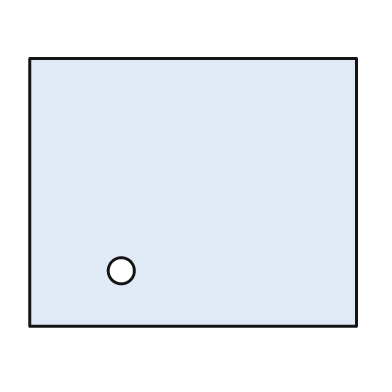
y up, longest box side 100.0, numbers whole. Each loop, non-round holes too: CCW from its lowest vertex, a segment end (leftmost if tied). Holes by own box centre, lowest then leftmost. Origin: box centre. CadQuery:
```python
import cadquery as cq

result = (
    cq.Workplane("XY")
    .moveTo(-50.0, -41.0)
    .lineTo(50.0, -41.0)
    .lineTo(50.0, 41.0)
    .lineTo(-50.0, 41.0)
    .close()
    .moveTo(-22.0, -24.0)
    .circle(4.0)
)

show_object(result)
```